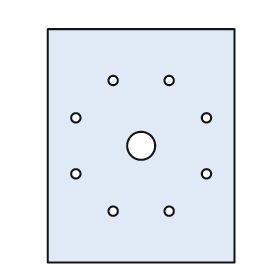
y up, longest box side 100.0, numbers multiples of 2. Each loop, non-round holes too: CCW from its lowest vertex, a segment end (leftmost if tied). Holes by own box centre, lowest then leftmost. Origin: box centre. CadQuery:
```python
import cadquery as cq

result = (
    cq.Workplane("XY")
    .moveTo(-40.0, -50.0)
    .lineTo(40.0, -50.0)
    .lineTo(40.0, 50.0)
    .lineTo(-40.0, 50.0)
    .close()
    .moveTo(-12.0, -28.0)
    .circle(2.0)
    .moveTo(12.0, -28.0)
    .circle(2.0)
    .moveTo(-28.0, -12.0)
    .circle(2.0)
    .moveTo(28.0, -12.0)
    .circle(2.0)
    .moveTo(0.0, 0.0)
    .circle(6.0)
    .moveTo(-28.0, 12.0)
    .circle(2.0)
    .moveTo(28.0, 12.0)
    .circle(2.0)
    .moveTo(-12.0, 28.0)
    .circle(2.0)
    .moveTo(12.0, 28.0)
    .circle(2.0)
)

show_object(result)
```